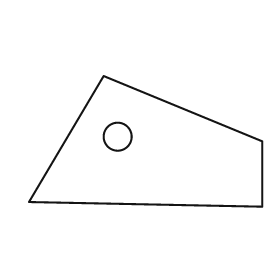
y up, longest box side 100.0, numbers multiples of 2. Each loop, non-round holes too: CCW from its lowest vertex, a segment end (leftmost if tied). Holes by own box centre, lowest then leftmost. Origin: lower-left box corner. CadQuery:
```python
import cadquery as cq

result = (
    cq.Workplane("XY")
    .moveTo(100.0, 0.0)
    .lineTo(100.0, 28.0)
    .lineTo(32.0, 56.0)
    .lineTo(0.0, 2.0)
    .close()
    .moveTo(38.0, 30.0)
    .circle(6.0)
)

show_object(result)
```